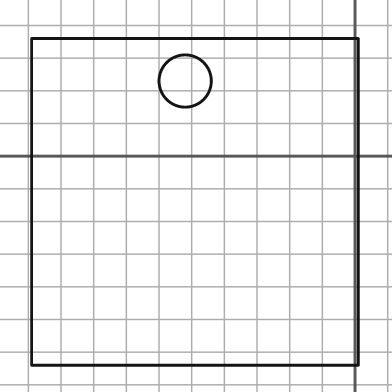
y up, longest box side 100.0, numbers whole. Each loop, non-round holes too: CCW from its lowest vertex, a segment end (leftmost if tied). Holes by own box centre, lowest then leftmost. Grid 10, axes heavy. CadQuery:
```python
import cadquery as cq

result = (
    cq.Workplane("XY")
    .moveTo(-99.0, -64.0)
    .lineTo(1.0, -64.0)
    .lineTo(1.0, 36.0)
    .lineTo(-99.0, 36.0)
    .close()
    .moveTo(-52.0, 23.0)
    .circle(8.0)
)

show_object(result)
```